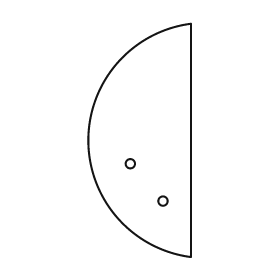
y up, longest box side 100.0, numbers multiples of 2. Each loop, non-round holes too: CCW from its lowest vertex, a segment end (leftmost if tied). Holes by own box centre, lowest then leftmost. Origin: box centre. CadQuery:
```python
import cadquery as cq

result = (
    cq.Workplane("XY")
    .moveTo(22.0, -50.0)
    .lineTo(22.0, 50.0)
    .threePointArc((-22.0, 0.0), (22.0, -50.0))
    .close()
    .moveTo(10.0, -26.0)
    .circle(2.0)
    .moveTo(-4.0, -10.0)
    .circle(2.0)
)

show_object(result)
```